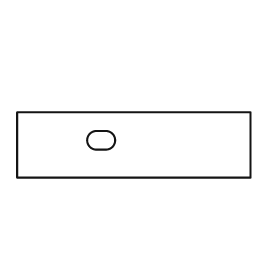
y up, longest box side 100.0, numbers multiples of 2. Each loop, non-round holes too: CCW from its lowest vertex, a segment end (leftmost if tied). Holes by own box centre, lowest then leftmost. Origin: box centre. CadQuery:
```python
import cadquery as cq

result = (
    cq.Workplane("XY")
    .moveTo(-50.0, -14.0)
    .lineTo(50.0, -14.0)
    .lineTo(50.0, 14.0)
    .lineTo(-50.0, 14.0)
    .close()
    .moveTo(-16.0, -2.0)
    .lineTo(-12.0, -2.0)
    .threePointArc((-8.0, 2.0), (-12.0, 6.0))
    .lineTo(-16.0, 6.0)
    .threePointArc((-20.0, 2.0), (-16.0, -2.0))
    .close()
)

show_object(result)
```